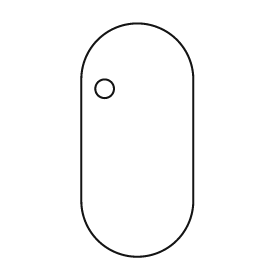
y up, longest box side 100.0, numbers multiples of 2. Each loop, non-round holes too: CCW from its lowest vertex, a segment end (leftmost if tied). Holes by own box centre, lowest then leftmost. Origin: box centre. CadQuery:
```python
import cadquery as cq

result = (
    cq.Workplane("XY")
    .moveTo(-24.0, -26.0)
    .threePointArc((0.0, -50.0), (24.0, -26.0))
    .lineTo(24.0, 26.0)
    .threePointArc((0.0, 50.0), (-24.0, 26.0))
    .close()
    .moveTo(-14.0, 22.0)
    .circle(4.0)
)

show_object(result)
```